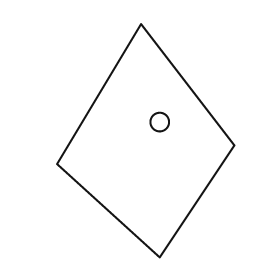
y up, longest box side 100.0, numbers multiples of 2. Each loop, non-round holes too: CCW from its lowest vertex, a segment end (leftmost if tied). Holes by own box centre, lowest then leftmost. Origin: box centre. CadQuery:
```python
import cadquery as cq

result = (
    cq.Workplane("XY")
    .moveTo(6.0, -50.0)
    .lineTo(38.0, -2.0)
    .lineTo(-2.0, 50.0)
    .lineTo(-38.0, -10.0)
    .close()
    .moveTo(6.0, 8.0)
    .circle(4.0)
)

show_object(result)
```